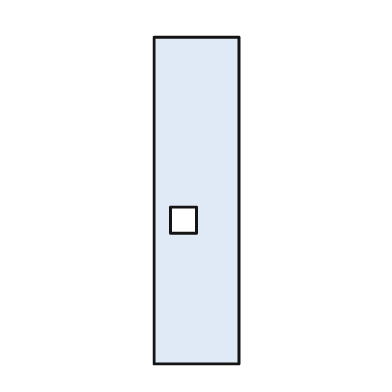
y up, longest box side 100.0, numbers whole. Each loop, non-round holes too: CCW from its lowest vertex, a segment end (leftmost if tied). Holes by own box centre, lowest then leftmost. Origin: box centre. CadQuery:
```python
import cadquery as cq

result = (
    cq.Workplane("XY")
    .moveTo(-13.0, -50.0)
    .lineTo(13.0, -50.0)
    .lineTo(13.0, 50.0)
    .lineTo(-13.0, 50.0)
    .close()
    .moveTo(-8.0, -10.0)
    .lineTo(0.0, -10.0)
    .lineTo(0.0, -2.0)
    .lineTo(-8.0, -2.0)
    .close()
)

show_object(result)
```